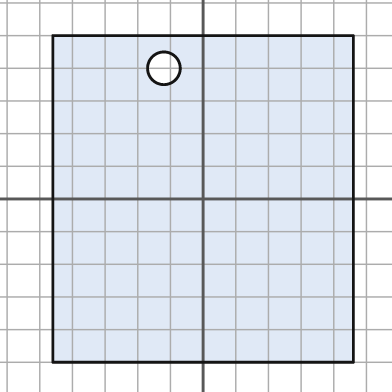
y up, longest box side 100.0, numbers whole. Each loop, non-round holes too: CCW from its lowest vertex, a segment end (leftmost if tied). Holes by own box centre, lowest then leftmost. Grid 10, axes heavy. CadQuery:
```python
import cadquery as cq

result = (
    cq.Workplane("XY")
    .moveTo(-46.0, -50.0)
    .lineTo(46.0, -50.0)
    .lineTo(46.0, 50.0)
    .lineTo(-46.0, 50.0)
    .close()
    .moveTo(-12.0, 40.0)
    .circle(5.0)
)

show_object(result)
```